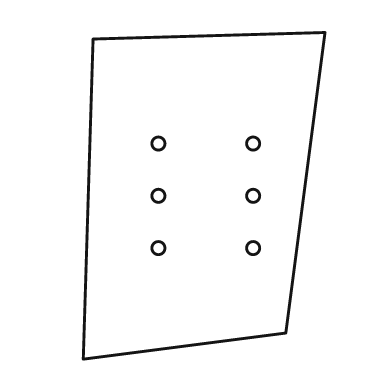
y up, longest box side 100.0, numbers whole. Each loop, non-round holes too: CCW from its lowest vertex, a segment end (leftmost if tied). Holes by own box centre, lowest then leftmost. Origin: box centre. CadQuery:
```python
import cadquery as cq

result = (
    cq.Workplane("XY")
    .moveTo(-37.0, -50.0)
    .lineTo(25.0, -42.0)
    .lineTo(37.0, 50.0)
    .lineTo(-34.0, 48.0)
    .close()
    .moveTo(-14.0, -16.0)
    .circle(2.0)
    .moveTo(15.0, -16.0)
    .circle(2.0)
    .moveTo(-14.0, 0.0)
    .circle(2.0)
    .moveTo(15.0, 0.0)
    .circle(2.0)
    .moveTo(-14.0, 16.0)
    .circle(2.0)
    .moveTo(15.0, 16.0)
    .circle(2.0)
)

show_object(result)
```